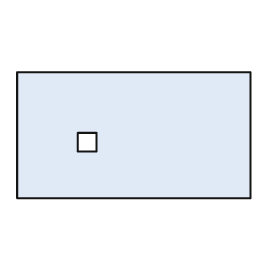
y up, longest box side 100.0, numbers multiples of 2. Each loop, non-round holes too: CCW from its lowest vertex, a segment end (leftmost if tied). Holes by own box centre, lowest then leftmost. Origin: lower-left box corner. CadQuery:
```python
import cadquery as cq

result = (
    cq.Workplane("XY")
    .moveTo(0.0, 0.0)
    .lineTo(100.0, 0.0)
    .lineTo(100.0, 54.0)
    .lineTo(0.0, 54.0)
    .close()
    .moveTo(26.0, 20.0)
    .lineTo(34.0, 20.0)
    .lineTo(34.0, 28.0)
    .lineTo(26.0, 28.0)
    .close()
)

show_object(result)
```